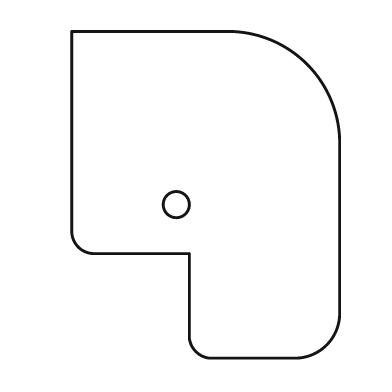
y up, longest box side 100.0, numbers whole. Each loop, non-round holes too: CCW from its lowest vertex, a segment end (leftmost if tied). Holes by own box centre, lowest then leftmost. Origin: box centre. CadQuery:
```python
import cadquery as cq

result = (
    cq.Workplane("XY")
    .moveTo(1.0, -50.0)
    .lineTo(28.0, -50.0)
    .threePointArc((37.0, -46.0), (41.0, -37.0))
    .lineTo(41.0, 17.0)
    .threePointArc((31.0, 40.0), (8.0, 50.0))
    .lineTo(-41.0, 50.0)
    .lineTo(-41.0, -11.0)
    .threePointArc((-39.0, -16.0), (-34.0, -18.0))
    .lineTo(-5.0, -18.0)
    .lineTo(-5.0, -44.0)
    .threePointArc((-3.0, -48.0), (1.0, -50.0))
    .close()
    .moveTo(-9.0, -3.0)
    .circle(4.0)
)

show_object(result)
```